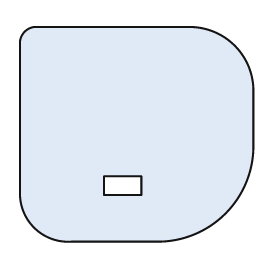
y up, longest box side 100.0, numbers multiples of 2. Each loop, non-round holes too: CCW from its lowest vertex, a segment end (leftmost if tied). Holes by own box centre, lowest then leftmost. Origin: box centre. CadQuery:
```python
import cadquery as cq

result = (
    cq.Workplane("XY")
    .moveTo(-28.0, -46.0)
    .lineTo(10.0, -46.0)
    .threePointArc((38.0, -34.0), (50.0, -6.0))
    .lineTo(50.0, 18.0)
    .threePointArc((42.0, 38.0), (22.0, 46.0))
    .lineTo(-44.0, 46.0)
    .threePointArc((-48.0, 44.0), (-50.0, 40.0))
    .lineTo(-50.0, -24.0)
    .threePointArc((-44.0, -40.0), (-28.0, -46.0))
    .close()
    .moveTo(-14.0, -26.0)
    .lineTo(2.0, -26.0)
    .lineTo(2.0, -18.0)
    .lineTo(-14.0, -18.0)
    .close()
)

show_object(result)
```